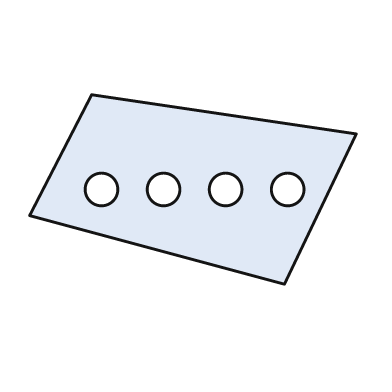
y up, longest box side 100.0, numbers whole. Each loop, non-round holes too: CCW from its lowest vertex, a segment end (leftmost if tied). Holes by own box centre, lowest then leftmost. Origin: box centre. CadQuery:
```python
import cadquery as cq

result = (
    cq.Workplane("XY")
    .moveTo(28.0, -29.0)
    .lineTo(50.0, 17.0)
    .lineTo(-31.0, 29.0)
    .lineTo(-50.0, -8.0)
    .close()
    .moveTo(-28.0, 0.0)
    .circle(5.0)
    .moveTo(-9.0, 0.0)
    .circle(5.0)
    .moveTo(10.0, 0.0)
    .circle(5.0)
    .moveTo(29.0, 0.0)
    .circle(5.0)
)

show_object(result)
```